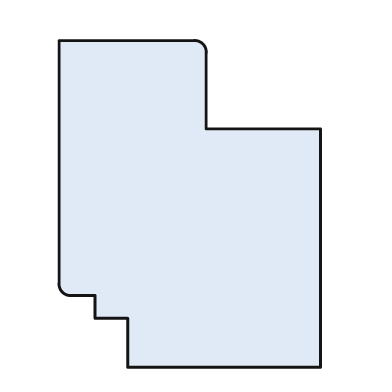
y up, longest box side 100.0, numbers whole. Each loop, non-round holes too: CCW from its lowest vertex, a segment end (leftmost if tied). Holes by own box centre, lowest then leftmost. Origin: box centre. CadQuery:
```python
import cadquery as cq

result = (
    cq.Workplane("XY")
    .moveTo(-19.0, -50.0)
    .lineTo(40.0, -50.0)
    .lineTo(40.0, 23.0)
    .lineTo(5.0, 23.0)
    .lineTo(5.0, 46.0)
    .threePointArc((4.0, 49.0), (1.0, 50.0))
    .lineTo(-40.0, 50.0)
    .lineTo(-40.0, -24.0)
    .threePointArc((-39.0, -27.0), (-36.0, -28.0))
    .lineTo(-29.0, -28.0)
    .lineTo(-29.0, -35.0)
    .lineTo(-19.0, -35.0)
    .close()
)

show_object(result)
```